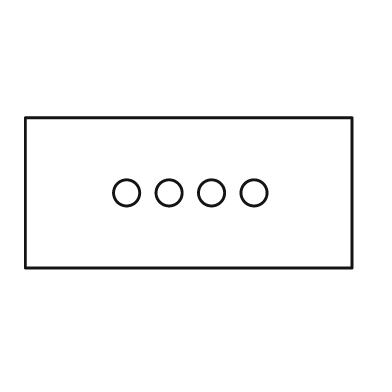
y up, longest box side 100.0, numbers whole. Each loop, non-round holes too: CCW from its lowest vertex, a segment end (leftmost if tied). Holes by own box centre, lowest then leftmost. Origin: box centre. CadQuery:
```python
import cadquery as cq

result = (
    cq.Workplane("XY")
    .moveTo(-50.0, -23.0)
    .lineTo(50.0, -23.0)
    .lineTo(50.0, 23.0)
    .lineTo(-50.0, 23.0)
    .close()
    .moveTo(-19.0, 0.0)
    .circle(4.0)
    .moveTo(-6.0, 0.0)
    .circle(4.0)
    .moveTo(7.0, 0.0)
    .circle(4.0)
    .moveTo(20.0, 0.0)
    .circle(4.0)
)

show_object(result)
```